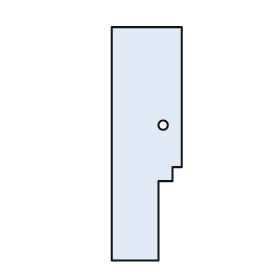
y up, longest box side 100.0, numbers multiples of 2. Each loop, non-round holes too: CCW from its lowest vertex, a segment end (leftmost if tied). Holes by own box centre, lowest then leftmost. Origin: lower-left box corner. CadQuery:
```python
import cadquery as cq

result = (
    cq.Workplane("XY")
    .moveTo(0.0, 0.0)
    .lineTo(20.0, 0.0)
    .lineTo(20.0, 34.0)
    .lineTo(26.0, 34.0)
    .lineTo(26.0, 40.0)
    .lineTo(30.0, 40.0)
    .lineTo(30.0, 100.0)
    .lineTo(0.0, 100.0)
    .close()
    .moveTo(22.0, 58.0)
    .circle(2.0)
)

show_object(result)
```